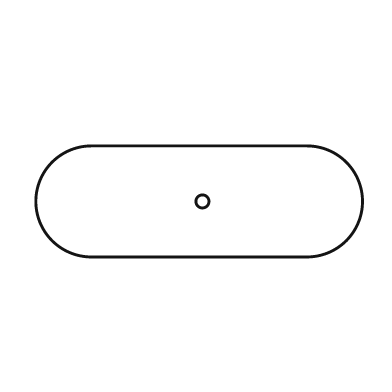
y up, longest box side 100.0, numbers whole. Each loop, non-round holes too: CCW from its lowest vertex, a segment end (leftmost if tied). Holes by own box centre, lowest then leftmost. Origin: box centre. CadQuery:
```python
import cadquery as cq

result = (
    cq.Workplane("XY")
    .moveTo(-33.0, -17.0)
    .lineTo(33.0, -17.0)
    .threePointArc((50.0, 0.0), (33.0, 17.0))
    .lineTo(-33.0, 17.0)
    .threePointArc((-50.0, 0.0), (-33.0, -17.0))
    .close()
    .moveTo(1.0, 0.0)
    .circle(2.0)
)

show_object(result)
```